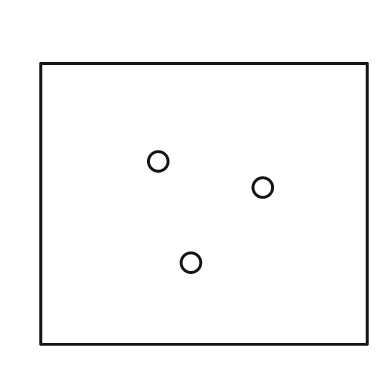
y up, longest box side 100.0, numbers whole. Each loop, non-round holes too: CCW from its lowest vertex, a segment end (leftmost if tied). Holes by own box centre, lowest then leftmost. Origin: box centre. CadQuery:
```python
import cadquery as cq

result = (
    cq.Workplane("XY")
    .moveTo(-50.0, -43.0)
    .lineTo(50.0, -43.0)
    .lineTo(50.0, 43.0)
    .lineTo(-50.0, 43.0)
    .close()
    .moveTo(-4.0, -18.0)
    .circle(3.0)
    .moveTo(18.0, 5.0)
    .circle(3.0)
    .moveTo(-14.0, 13.0)
    .circle(3.0)
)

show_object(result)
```